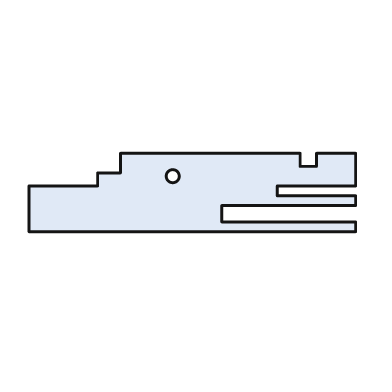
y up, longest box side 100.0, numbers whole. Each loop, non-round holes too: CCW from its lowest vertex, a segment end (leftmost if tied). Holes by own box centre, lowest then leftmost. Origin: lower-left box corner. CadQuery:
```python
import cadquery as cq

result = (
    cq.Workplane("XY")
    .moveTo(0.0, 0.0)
    .lineTo(100.0, 0.0)
    .lineTo(100.0, 3.0)
    .lineTo(59.0, 3.0)
    .lineTo(59.0, 8.0)
    .lineTo(100.0, 8.0)
    .lineTo(100.0, 11.0)
    .lineTo(76.0, 11.0)
    .lineTo(76.0, 14.0)
    .lineTo(100.0, 14.0)
    .lineTo(100.0, 24.0)
    .lineTo(88.0, 24.0)
    .lineTo(88.0, 20.0)
    .lineTo(83.0, 20.0)
    .lineTo(83.0, 24.0)
    .lineTo(28.0, 24.0)
    .lineTo(28.0, 18.0)
    .lineTo(21.0, 18.0)
    .lineTo(21.0, 14.0)
    .lineTo(0.0, 14.0)
    .close()
    .moveTo(44.0, 17.0)
    .circle(2.0)
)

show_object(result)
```